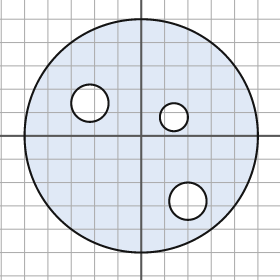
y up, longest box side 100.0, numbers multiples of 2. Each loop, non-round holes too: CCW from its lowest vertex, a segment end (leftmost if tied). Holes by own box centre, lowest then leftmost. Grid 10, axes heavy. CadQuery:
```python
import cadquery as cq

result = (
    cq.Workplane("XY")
    .moveTo(0.0, 0.0)
    .circle(50.0)
    .moveTo(20.0, -28.0)
    .circle(8.0)
    .moveTo(14.0, 8.0)
    .circle(6.0)
    .moveTo(-22.0, 14.0)
    .circle(8.0)
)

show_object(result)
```